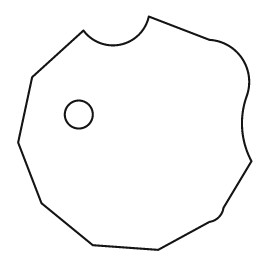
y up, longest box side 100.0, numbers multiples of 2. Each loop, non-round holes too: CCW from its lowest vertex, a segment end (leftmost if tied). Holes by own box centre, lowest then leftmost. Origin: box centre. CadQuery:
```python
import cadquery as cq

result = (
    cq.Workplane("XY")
    .moveTo(10.0, -50.0)
    .lineTo(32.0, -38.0)
    .threePointArc((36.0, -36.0), (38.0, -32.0))
    .lineTo(50.0, -12.0)
    .threePointArc((46.0, 2.0), (48.0, 16.0))
    .threePointArc((46.0, 32.0), (32.0, 40.0))
    .lineTo(6.0, 50.0)
    .threePointArc((-6.0, 38.0), (-22.0, 44.0))
    .lineTo(-44.0, 24.0)
    .lineTo(-50.0, -4.0)
    .lineTo(-40.0, -30.0)
    .lineTo(-18.0, -48.0)
    .close()
    .moveTo(-24.0, 8.0)
    .circle(6.0)
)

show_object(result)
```